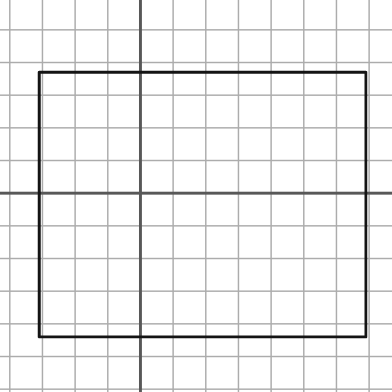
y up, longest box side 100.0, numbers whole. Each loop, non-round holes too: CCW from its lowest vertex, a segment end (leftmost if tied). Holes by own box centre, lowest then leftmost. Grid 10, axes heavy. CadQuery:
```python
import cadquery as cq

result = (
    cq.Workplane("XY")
    .moveTo(-31.0, -44.0)
    .lineTo(69.0, -44.0)
    .lineTo(69.0, 37.0)
    .lineTo(-31.0, 37.0)
    .close()
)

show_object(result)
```